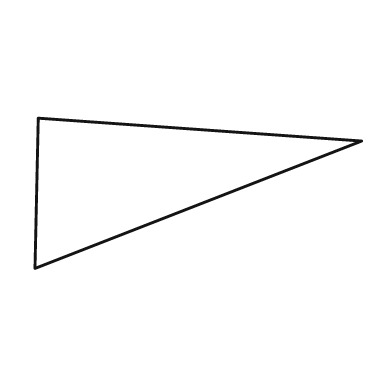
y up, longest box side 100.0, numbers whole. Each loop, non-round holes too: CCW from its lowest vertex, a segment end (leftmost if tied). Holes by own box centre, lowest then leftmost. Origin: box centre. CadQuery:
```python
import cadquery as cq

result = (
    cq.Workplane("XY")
    .moveTo(-50.0, -23.0)
    .lineTo(50.0, 16.0)
    .lineTo(-49.0, 23.0)
    .close()
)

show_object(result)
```